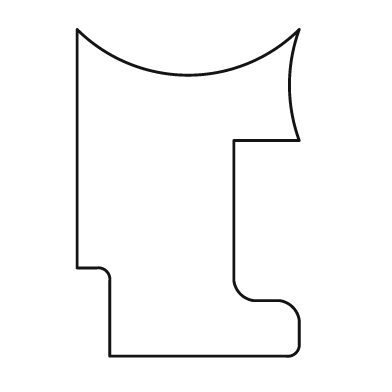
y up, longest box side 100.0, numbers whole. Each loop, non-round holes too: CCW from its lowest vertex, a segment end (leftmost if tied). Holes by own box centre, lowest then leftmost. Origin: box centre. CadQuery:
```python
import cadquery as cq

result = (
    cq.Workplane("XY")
    .moveTo(-24.0, -50.0)
    .lineTo(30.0, -50.0)
    .threePointArc((33.0, -49.0), (34.0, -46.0))
    .lineTo(34.0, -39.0)
    .threePointArc((32.0, -35.0), (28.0, -33.0))
    .lineTo(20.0, -33.0)
    .threePointArc((16.0, -31.0), (14.0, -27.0))
    .lineTo(14.0, 16.0)
    .lineTo(34.0, 16.0)
    .threePointArc((31.0, 33.0), (34.0, 50.0))
    .threePointArc((0.0, 36.0), (-34.0, 50.0))
    .lineTo(-34.0, -23.0)
    .lineTo(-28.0, -23.0)
    .threePointArc((-25.0, -24.0), (-24.0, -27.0))
    .close()
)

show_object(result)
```